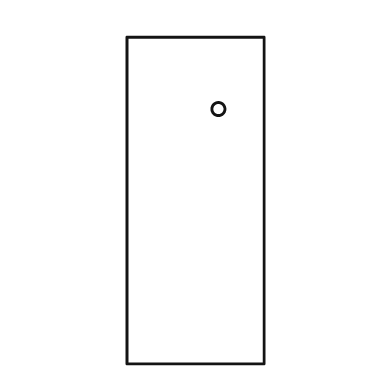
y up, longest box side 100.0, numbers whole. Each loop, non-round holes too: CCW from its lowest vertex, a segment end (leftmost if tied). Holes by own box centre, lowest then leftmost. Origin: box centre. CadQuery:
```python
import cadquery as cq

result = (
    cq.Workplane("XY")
    .moveTo(-21.0, -50.0)
    .lineTo(21.0, -50.0)
    .lineTo(21.0, 50.0)
    .lineTo(-21.0, 50.0)
    .close()
    .moveTo(7.0, 28.0)
    .circle(2.0)
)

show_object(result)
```